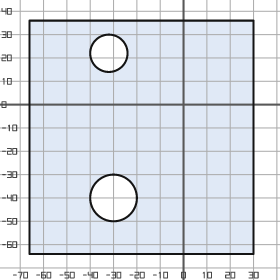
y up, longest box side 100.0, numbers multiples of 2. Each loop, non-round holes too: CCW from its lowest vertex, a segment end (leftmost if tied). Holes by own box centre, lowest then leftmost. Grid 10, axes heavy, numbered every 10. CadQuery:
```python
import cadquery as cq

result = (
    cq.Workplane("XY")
    .moveTo(-66.0, -64.0)
    .lineTo(30.0, -64.0)
    .lineTo(30.0, 36.0)
    .lineTo(-66.0, 36.0)
    .close()
    .moveTo(-30.0, -40.0)
    .circle(10.0)
    .moveTo(-32.0, 22.0)
    .circle(8.0)
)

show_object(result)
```